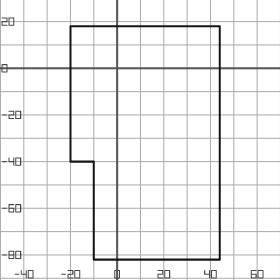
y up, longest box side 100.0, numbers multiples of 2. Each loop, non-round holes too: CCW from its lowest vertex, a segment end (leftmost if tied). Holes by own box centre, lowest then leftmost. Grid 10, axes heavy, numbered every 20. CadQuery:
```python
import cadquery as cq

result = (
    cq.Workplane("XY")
    .moveTo(-10.0, -82.0)
    .lineTo(44.0, -82.0)
    .lineTo(44.0, 18.0)
    .lineTo(-20.0, 18.0)
    .lineTo(-20.0, -40.0)
    .lineTo(-10.0, -40.0)
    .close()
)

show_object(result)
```